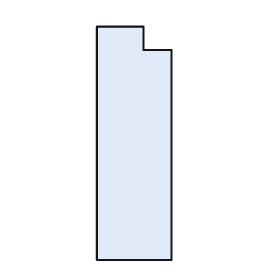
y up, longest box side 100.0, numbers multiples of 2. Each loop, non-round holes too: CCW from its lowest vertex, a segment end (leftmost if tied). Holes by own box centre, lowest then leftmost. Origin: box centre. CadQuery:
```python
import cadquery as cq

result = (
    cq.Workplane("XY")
    .moveTo(-16.0, -50.0)
    .lineTo(16.0, -50.0)
    .lineTo(16.0, 40.0)
    .lineTo(4.0, 40.0)
    .lineTo(4.0, 50.0)
    .lineTo(-16.0, 50.0)
    .close()
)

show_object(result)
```